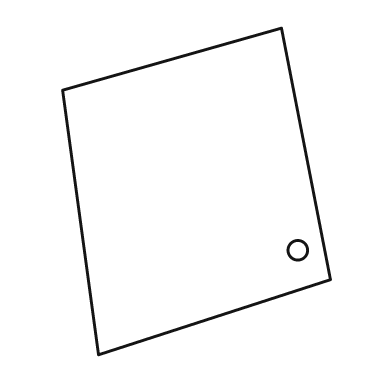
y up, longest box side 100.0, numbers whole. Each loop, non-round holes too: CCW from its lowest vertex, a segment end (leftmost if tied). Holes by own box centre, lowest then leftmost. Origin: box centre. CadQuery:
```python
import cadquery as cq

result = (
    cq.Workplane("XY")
    .moveTo(-30.0, -50.0)
    .lineTo(41.0, -27.0)
    .lineTo(26.0, 50.0)
    .lineTo(-41.0, 31.0)
    .close()
    .moveTo(31.0, -18.0)
    .circle(3.0)
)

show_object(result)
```